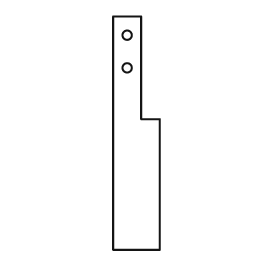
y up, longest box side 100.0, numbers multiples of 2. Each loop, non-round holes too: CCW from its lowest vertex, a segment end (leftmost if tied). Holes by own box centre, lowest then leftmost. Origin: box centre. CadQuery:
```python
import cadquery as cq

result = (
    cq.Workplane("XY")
    .moveTo(-10.0, -50.0)
    .lineTo(10.0, -50.0)
    .lineTo(10.0, 6.0)
    .lineTo(2.0, 6.0)
    .lineTo(2.0, 50.0)
    .lineTo(-10.0, 50.0)
    .close()
    .moveTo(-4.0, 28.0)
    .circle(2.0)
    .moveTo(-4.0, 42.0)
    .circle(2.0)
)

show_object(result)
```